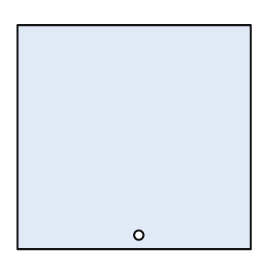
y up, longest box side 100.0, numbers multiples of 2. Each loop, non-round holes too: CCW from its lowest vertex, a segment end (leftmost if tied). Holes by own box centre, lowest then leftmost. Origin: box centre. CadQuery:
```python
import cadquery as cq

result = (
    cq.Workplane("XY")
    .moveTo(-50.0, -48.0)
    .lineTo(50.0, -48.0)
    .lineTo(50.0, 48.0)
    .lineTo(-50.0, 48.0)
    .close()
    .moveTo(2.0, -42.0)
    .circle(2.0)
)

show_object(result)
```